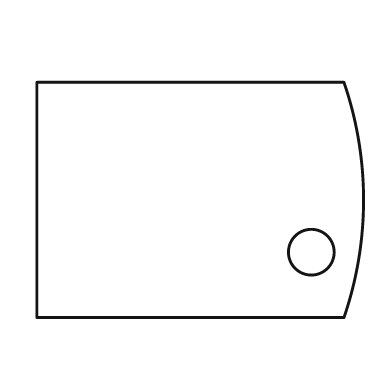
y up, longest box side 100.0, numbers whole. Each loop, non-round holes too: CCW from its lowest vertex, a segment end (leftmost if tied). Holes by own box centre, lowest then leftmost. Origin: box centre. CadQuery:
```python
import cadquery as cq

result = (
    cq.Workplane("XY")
    .moveTo(-50.0, -36.0)
    .lineTo(44.0, -36.0)
    .threePointArc((50.0, 0.0), (44.0, 36.0))
    .lineTo(-50.0, 36.0)
    .close()
    .moveTo(34.0, -16.0)
    .circle(7.0)
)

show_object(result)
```